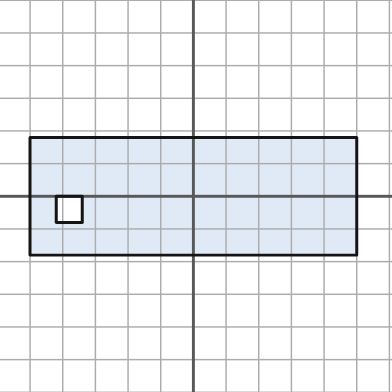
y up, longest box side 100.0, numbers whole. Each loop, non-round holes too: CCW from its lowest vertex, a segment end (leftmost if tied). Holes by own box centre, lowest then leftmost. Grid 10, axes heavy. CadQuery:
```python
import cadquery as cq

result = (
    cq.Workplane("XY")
    .moveTo(-50.0, -18.0)
    .lineTo(50.0, -18.0)
    .lineTo(50.0, 18.0)
    .lineTo(-50.0, 18.0)
    .close()
    .moveTo(-42.0, -8.0)
    .lineTo(-34.0, -8.0)
    .lineTo(-34.0, 0.0)
    .lineTo(-42.0, 0.0)
    .close()
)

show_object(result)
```